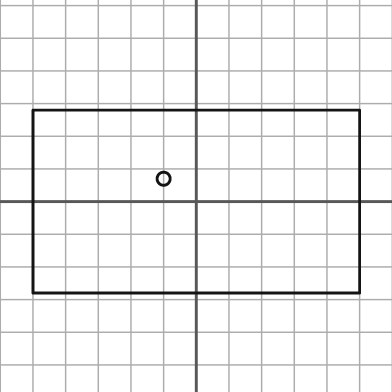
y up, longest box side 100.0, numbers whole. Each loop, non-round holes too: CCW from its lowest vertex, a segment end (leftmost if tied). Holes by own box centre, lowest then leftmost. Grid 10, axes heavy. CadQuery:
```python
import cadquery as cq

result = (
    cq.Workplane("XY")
    .moveTo(-50.0, -28.0)
    .lineTo(50.0, -28.0)
    .lineTo(50.0, 28.0)
    .lineTo(-50.0, 28.0)
    .close()
    .moveTo(-10.0, 7.0)
    .circle(2.0)
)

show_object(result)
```